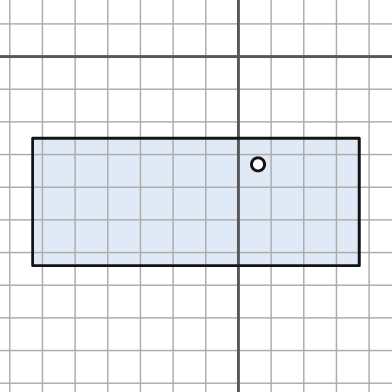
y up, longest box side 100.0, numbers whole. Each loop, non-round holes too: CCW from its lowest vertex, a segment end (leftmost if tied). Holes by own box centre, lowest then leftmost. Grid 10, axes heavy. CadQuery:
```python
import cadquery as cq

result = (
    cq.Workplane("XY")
    .moveTo(-63.0, -64.0)
    .lineTo(37.0, -64.0)
    .lineTo(37.0, -25.0)
    .lineTo(-63.0, -25.0)
    .close()
    .moveTo(6.0, -33.0)
    .circle(2.0)
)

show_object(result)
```